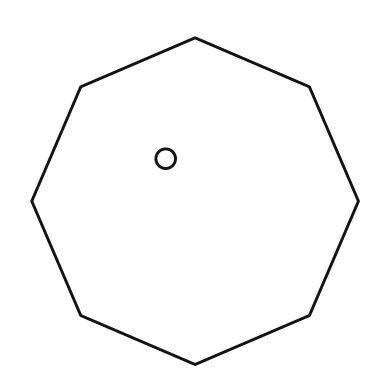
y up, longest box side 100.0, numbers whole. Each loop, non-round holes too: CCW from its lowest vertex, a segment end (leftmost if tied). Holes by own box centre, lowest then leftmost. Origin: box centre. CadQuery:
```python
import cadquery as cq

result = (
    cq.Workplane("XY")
    .moveTo(0.0, -50.0)
    .lineTo(35.0, -35.0)
    .lineTo(50.0, 0.0)
    .lineTo(35.0, 35.0)
    .lineTo(0.0, 50.0)
    .lineTo(-35.0, 35.0)
    .lineTo(-50.0, 0.0)
    .lineTo(-35.0, -35.0)
    .close()
    .moveTo(-9.0, 13.0)
    .circle(3.0)
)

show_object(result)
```